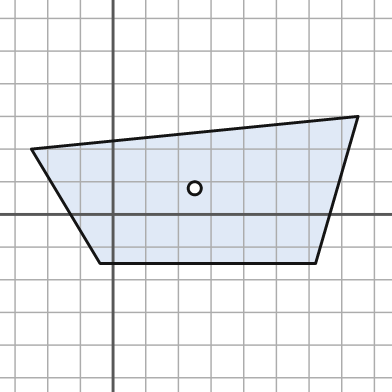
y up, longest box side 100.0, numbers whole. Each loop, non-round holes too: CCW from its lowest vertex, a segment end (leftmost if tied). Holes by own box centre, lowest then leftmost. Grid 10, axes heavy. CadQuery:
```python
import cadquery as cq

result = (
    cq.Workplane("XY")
    .moveTo(-4.0, -15.0)
    .lineTo(62.0, -15.0)
    .lineTo(75.0, 30.0)
    .lineTo(-25.0, 20.0)
    .close()
    .moveTo(25.0, 8.0)
    .circle(2.0)
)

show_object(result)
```